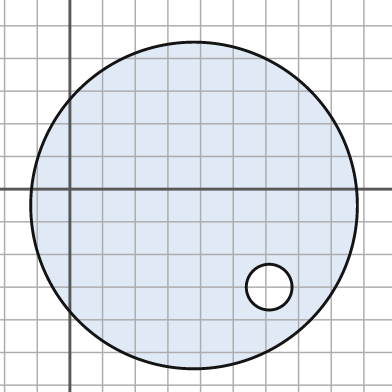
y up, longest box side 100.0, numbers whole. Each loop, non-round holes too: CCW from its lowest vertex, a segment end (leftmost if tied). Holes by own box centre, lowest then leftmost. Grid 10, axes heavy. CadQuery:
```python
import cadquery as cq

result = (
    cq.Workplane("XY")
    .moveTo(38.0, -5.0)
    .circle(50.0)
    .moveTo(61.0, -30.0)
    .circle(7.0)
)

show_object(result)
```